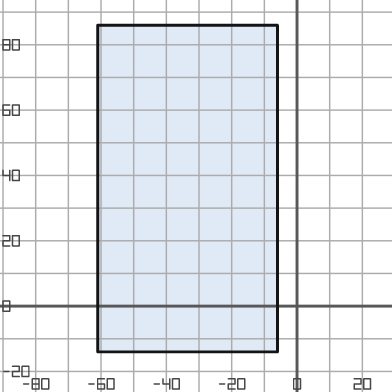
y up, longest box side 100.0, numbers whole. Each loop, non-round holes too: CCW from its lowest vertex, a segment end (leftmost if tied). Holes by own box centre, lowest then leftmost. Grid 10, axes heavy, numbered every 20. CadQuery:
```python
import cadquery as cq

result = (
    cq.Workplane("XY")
    .moveTo(-61.0, -14.0)
    .lineTo(-6.0, -14.0)
    .lineTo(-6.0, 86.0)
    .lineTo(-61.0, 86.0)
    .close()
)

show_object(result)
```